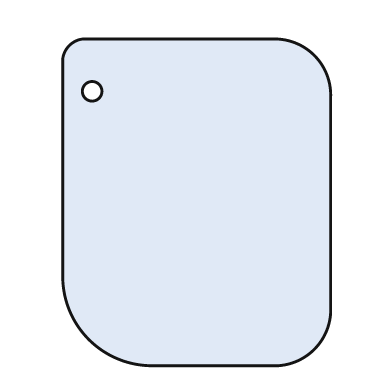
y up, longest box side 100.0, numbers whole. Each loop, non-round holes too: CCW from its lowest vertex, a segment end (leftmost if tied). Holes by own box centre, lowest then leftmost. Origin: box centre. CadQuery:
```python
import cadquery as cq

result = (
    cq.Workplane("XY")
    .moveTo(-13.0, -50.0)
    .lineTo(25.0, -50.0)
    .threePointArc((36.0, -45.0), (41.0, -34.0))
    .lineTo(41.0, 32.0)
    .threePointArc((36.0, 45.0), (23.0, 50.0))
    .lineTo(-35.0, 50.0)
    .threePointArc((-39.0, 48.0), (-41.0, 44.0))
    .lineTo(-41.0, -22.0)
    .threePointArc((-33.0, -42.0), (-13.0, -50.0))
    .close()
    .moveTo(-32.0, 34.0)
    .circle(3.0)
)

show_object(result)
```